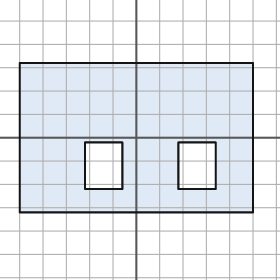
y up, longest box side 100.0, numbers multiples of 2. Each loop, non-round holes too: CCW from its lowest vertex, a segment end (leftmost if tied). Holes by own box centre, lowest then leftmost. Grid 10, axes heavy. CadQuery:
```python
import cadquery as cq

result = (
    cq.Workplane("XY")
    .moveTo(-50.0, -32.0)
    .lineTo(50.0, -32.0)
    .lineTo(50.0, 32.0)
    .lineTo(-50.0, 32.0)
    .close()
    .moveTo(-22.0, -22.0)
    .lineTo(-6.0, -22.0)
    .lineTo(-6.0, -2.0)
    .lineTo(-22.0, -2.0)
    .close()
    .moveTo(18.0, -22.0)
    .lineTo(34.0, -22.0)
    .lineTo(34.0, -2.0)
    .lineTo(18.0, -2.0)
    .close()
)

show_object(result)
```